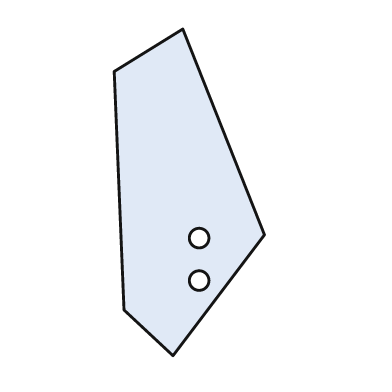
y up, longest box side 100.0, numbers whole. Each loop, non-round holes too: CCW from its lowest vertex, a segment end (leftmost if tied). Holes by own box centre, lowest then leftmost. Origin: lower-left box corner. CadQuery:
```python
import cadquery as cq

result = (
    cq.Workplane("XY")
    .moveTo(18.0, 0.0)
    .lineTo(46.0, 37.0)
    .lineTo(21.0, 100.0)
    .lineTo(0.0, 87.0)
    .lineTo(3.0, 14.0)
    .close()
    .moveTo(26.0, 23.0)
    .circle(3.0)
    .moveTo(26.0, 36.0)
    .circle(3.0)
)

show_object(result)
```